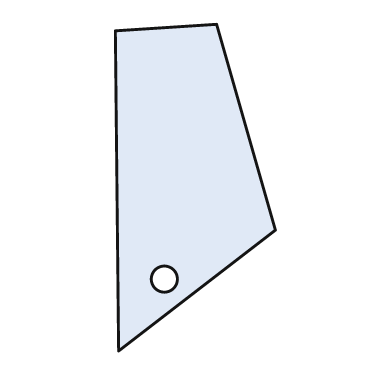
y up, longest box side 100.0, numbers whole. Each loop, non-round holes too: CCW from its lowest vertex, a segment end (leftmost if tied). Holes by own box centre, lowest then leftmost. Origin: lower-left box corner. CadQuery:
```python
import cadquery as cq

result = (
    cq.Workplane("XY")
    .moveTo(1.0, 0.0)
    .lineTo(49.0, 37.0)
    .lineTo(31.0, 100.0)
    .lineTo(0.0, 98.0)
    .close()
    .moveTo(15.0, 22.0)
    .circle(4.0)
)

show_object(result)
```